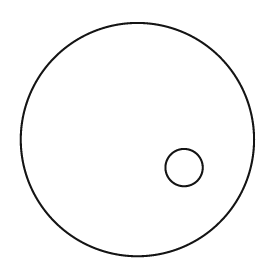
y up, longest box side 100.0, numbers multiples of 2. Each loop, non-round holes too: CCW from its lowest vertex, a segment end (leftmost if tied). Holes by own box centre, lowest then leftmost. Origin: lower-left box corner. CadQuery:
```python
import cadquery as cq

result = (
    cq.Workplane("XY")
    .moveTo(50.0, 50.0)
    .circle(50.0)
    .moveTo(70.0, 38.0)
    .circle(8.0)
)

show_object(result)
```